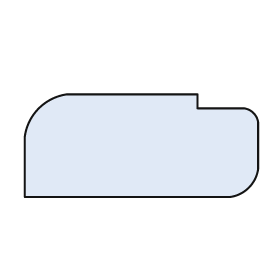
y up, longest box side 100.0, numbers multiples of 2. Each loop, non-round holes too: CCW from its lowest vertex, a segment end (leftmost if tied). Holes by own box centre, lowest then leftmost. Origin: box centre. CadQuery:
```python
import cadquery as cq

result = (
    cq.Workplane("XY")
    .moveTo(-50.0, -22.0)
    .lineTo(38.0, -22.0)
    .threePointArc((46.0, -18.0), (50.0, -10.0))
    .lineTo(50.0, 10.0)
    .threePointArc((48.0, 14.0), (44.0, 16.0))
    .lineTo(24.0, 16.0)
    .lineTo(24.0, 22.0)
    .lineTo(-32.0, 22.0)
    .threePointArc((-44.0, 16.0), (-50.0, 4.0))
    .close()
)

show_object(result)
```